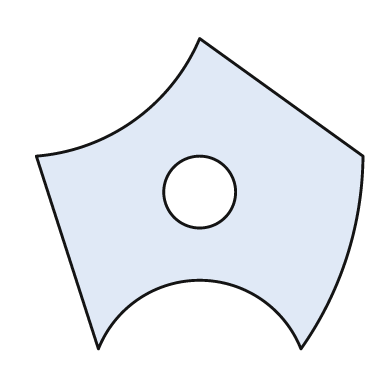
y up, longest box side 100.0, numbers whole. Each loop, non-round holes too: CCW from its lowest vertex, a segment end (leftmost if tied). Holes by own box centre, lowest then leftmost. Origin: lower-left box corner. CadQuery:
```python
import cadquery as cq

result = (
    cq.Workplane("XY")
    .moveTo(19.0, 0.0)
    .threePointArc((50.0, 21.0), (81.0, 0.0))
    .threePointArc((95.0, 28.0), (100.0, 59.0))
    .lineTo(50.0, 95.0)
    .threePointArc((30.0, 70.0), (0.0, 59.0))
    .close()
    .moveTo(50.0, 48.0)
    .circle(11.0)
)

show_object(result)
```